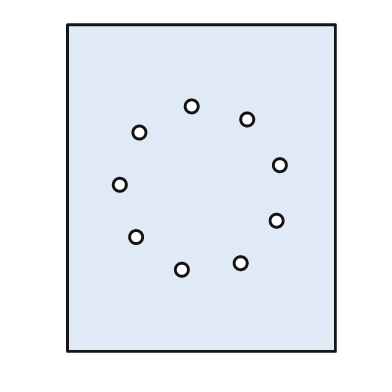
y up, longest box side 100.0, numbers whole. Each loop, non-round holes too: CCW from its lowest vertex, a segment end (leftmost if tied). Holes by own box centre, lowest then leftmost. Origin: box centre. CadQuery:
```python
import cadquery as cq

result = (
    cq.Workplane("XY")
    .moveTo(-41.0, -50.0)
    .lineTo(41.0, -50.0)
    .lineTo(41.0, 50.0)
    .lineTo(-41.0, 50.0)
    .close()
    .moveTo(-6.0, -25.0)
    .circle(2.0)
    .moveTo(12.0, -23.0)
    .circle(2.0)
    .moveTo(-20.0, -15.0)
    .circle(2.0)
    .moveTo(23.0, -10.0)
    .circle(2.0)
    .moveTo(-25.0, 1.0)
    .circle(2.0)
    .moveTo(24.0, 7.0)
    .circle(2.0)
    .moveTo(-19.0, 17.0)
    .circle(2.0)
    .moveTo(14.0, 21.0)
    .circle(2.0)
    .moveTo(-3.0, 25.0)
    .circle(2.0)
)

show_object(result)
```